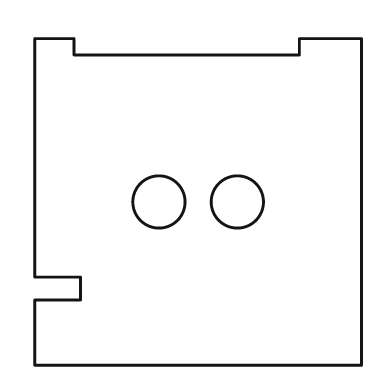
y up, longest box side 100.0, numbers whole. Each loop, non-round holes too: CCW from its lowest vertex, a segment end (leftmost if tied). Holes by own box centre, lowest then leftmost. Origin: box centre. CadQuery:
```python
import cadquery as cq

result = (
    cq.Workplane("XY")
    .moveTo(-50.0, -50.0)
    .lineTo(50.0, -50.0)
    .lineTo(50.0, 50.0)
    .lineTo(31.0, 50.0)
    .lineTo(31.0, 45.0)
    .lineTo(-38.0, 45.0)
    .lineTo(-38.0, 50.0)
    .lineTo(-50.0, 50.0)
    .lineTo(-50.0, -23.0)
    .lineTo(-36.0, -23.0)
    .lineTo(-36.0, -30.0)
    .lineTo(-50.0, -30.0)
    .close()
    .moveTo(-12.0, 0.0)
    .circle(8.0)
    .moveTo(12.0, 0.0)
    .circle(8.0)
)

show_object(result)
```